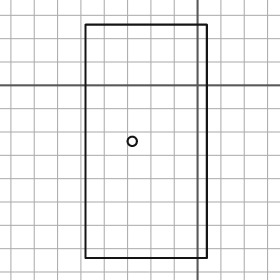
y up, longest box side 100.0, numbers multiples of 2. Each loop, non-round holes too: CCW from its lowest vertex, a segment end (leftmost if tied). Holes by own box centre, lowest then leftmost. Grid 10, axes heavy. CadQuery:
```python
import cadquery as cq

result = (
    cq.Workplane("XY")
    .moveTo(-48.0, -74.0)
    .lineTo(4.0, -74.0)
    .lineTo(4.0, 26.0)
    .lineTo(-48.0, 26.0)
    .close()
    .moveTo(-28.0, -24.0)
    .circle(2.0)
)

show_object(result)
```